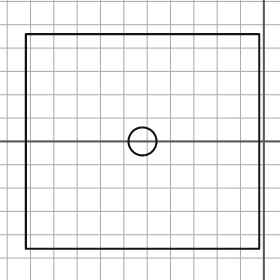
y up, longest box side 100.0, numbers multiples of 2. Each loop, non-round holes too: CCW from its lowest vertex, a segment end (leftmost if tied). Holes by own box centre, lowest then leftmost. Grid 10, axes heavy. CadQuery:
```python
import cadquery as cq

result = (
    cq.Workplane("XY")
    .moveTo(-102.0, -46.0)
    .lineTo(-2.0, -46.0)
    .lineTo(-2.0, 46.0)
    .lineTo(-102.0, 46.0)
    .close()
    .moveTo(-52.0, 0.0)
    .circle(6.0)
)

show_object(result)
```